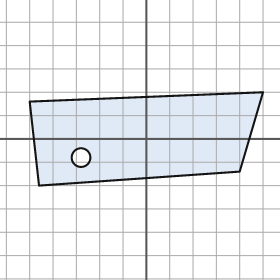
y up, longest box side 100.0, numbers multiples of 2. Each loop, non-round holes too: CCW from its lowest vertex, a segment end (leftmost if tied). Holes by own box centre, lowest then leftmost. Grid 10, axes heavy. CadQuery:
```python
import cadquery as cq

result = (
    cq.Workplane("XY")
    .moveTo(-46.0, -20.0)
    .lineTo(40.0, -14.0)
    .lineTo(50.0, 20.0)
    .lineTo(-50.0, 16.0)
    .close()
    .moveTo(-28.0, -8.0)
    .circle(4.0)
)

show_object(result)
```